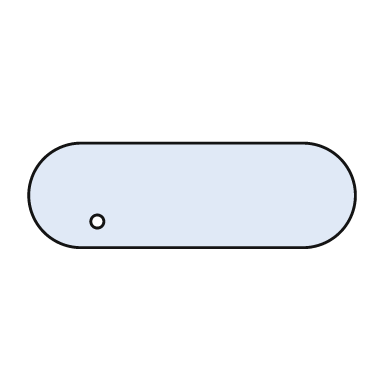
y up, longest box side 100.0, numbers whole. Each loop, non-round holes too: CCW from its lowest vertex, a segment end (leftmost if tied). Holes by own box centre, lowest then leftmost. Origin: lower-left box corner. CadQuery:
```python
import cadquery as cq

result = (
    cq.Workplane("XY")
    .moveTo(16.0, 0.0)
    .lineTo(84.0, 0.0)
    .threePointArc((100.0, 16.0), (84.0, 32.0))
    .lineTo(16.0, 32.0)
    .threePointArc((0.0, 16.0), (16.0, 0.0))
    .close()
    .moveTo(21.0, 8.0)
    .circle(2.0)
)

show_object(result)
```